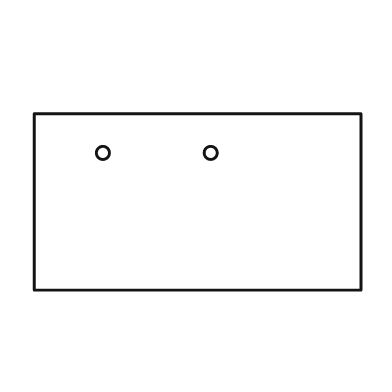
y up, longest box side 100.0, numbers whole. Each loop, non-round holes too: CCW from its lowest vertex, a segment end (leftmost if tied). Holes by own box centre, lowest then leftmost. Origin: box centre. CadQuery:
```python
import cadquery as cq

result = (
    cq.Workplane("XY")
    .moveTo(-50.0, -27.0)
    .lineTo(50.0, -27.0)
    .lineTo(50.0, 27.0)
    .lineTo(-50.0, 27.0)
    .close()
    .moveTo(-29.0, 15.0)
    .circle(2.0)
    .moveTo(4.0, 15.0)
    .circle(2.0)
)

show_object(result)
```